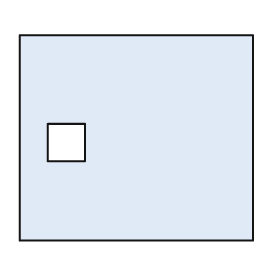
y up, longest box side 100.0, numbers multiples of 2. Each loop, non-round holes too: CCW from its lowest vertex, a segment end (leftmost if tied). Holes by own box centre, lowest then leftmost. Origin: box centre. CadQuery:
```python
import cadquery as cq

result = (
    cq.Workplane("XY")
    .moveTo(-50.0, -44.0)
    .lineTo(50.0, -44.0)
    .lineTo(50.0, 44.0)
    .lineTo(-50.0, 44.0)
    .close()
    .moveTo(-38.0, -10.0)
    .lineTo(-22.0, -10.0)
    .lineTo(-22.0, 6.0)
    .lineTo(-38.0, 6.0)
    .close()
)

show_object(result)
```